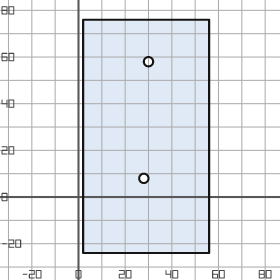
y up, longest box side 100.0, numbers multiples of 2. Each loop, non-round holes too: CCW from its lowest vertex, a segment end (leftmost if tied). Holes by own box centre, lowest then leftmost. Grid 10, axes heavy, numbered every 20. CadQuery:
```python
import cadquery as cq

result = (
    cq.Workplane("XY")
    .moveTo(2.0, -24.0)
    .lineTo(56.0, -24.0)
    .lineTo(56.0, 76.0)
    .lineTo(2.0, 76.0)
    .close()
    .moveTo(28.0, 8.0)
    .circle(2.0)
    .moveTo(30.0, 58.0)
    .circle(2.0)
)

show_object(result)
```